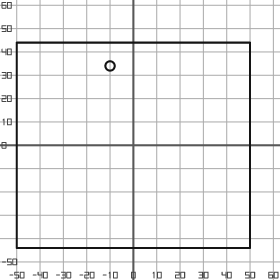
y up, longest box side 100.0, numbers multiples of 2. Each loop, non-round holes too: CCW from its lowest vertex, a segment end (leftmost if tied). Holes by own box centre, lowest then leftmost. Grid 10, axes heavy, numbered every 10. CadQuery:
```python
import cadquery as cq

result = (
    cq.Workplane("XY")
    .moveTo(-50.0, -44.0)
    .lineTo(50.0, -44.0)
    .lineTo(50.0, 44.0)
    .lineTo(-50.0, 44.0)
    .close()
    .moveTo(-10.0, 34.0)
    .circle(2.0)
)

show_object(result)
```